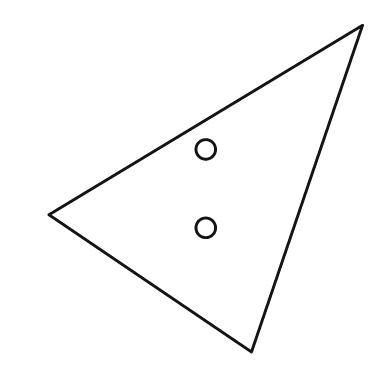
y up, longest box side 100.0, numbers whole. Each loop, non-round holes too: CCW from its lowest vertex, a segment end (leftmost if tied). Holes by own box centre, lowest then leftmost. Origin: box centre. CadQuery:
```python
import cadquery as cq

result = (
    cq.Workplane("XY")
    .moveTo(14.0, -50.0)
    .lineTo(48.0, 50.0)
    .lineTo(-48.0, -8.0)
    .close()
    .moveTo(0.0, -12.0)
    .circle(3.0)
    .moveTo(0.0, 12.0)
    .circle(3.0)
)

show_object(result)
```